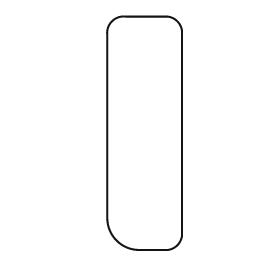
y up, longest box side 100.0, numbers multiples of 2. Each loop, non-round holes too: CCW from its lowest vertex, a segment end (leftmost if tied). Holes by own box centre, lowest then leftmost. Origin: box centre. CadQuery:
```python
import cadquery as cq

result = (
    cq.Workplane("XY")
    .moveTo(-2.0, -50.0)
    .lineTo(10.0, -50.0)
    .threePointArc((14.0, -48.0), (16.0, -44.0))
    .lineTo(16.0, 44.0)
    .threePointArc((14.0, 48.0), (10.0, 50.0))
    .lineTo(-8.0, 50.0)
    .threePointArc((-14.0, 48.0), (-16.0, 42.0))
    .lineTo(-16.0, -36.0)
    .threePointArc((-12.0, -46.0), (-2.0, -50.0))
    .close()
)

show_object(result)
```